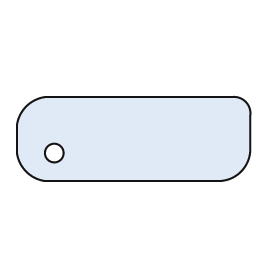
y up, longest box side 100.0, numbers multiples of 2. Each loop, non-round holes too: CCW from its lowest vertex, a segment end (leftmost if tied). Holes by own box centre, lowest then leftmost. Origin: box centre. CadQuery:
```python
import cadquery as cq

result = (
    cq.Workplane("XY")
    .moveTo(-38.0, -18.0)
    .lineTo(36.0, -18.0)
    .threePointArc((46.0, -14.0), (50.0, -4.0))
    .lineTo(50.0, 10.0)
    .threePointArc((48.0, 16.0), (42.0, 18.0))
    .lineTo(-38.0, 18.0)
    .threePointArc((-46.0, 14.0), (-50.0, 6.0))
    .lineTo(-50.0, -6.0)
    .threePointArc((-46.0, -14.0), (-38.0, -18.0))
    .close()
    .moveTo(-34.0, -6.0)
    .circle(4.0)
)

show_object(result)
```